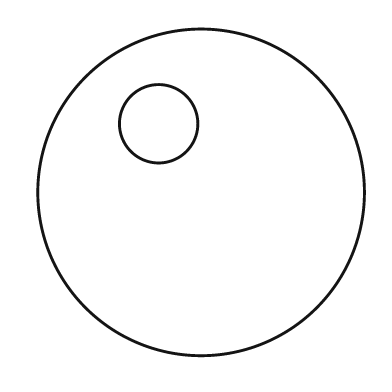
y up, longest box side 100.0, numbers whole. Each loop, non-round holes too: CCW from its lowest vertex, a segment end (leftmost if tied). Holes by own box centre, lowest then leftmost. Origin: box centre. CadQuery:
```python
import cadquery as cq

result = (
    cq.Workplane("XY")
    .moveTo(0.0, 0.0)
    .circle(50.0)
    .moveTo(-13.0, 21.0)
    .circle(12.0)
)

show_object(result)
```